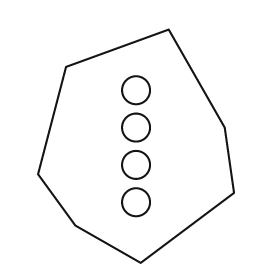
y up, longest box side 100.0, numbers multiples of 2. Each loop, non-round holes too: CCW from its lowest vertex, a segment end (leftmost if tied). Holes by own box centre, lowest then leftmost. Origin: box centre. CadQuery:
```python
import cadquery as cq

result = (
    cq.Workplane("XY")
    .moveTo(2.0, -50.0)
    .lineTo(42.0, -20.0)
    .lineTo(38.0, 8.0)
    .lineTo(14.0, 50.0)
    .lineTo(-30.0, 34.0)
    .lineTo(-42.0, -12.0)
    .lineTo(-26.0, -34.0)
    .close()
    .moveTo(0.0, -24.0)
    .circle(6.0)
    .moveTo(0.0, -8.0)
    .circle(6.0)
    .moveTo(0.0, 8.0)
    .circle(6.0)
    .moveTo(0.0, 24.0)
    .circle(6.0)
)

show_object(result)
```